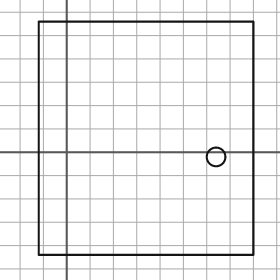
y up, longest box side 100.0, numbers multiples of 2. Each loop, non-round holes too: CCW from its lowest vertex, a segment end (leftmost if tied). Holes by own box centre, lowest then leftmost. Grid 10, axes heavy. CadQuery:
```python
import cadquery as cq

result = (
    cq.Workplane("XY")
    .moveTo(-12.0, -44.0)
    .lineTo(80.0, -44.0)
    .lineTo(80.0, 56.0)
    .lineTo(-12.0, 56.0)
    .close()
    .moveTo(64.0, -2.0)
    .circle(4.0)
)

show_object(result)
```